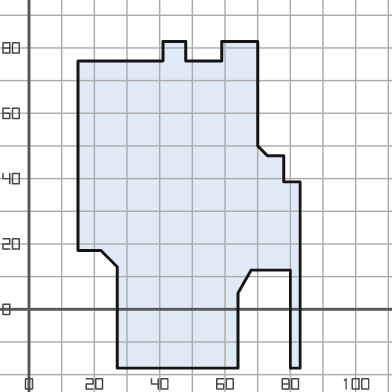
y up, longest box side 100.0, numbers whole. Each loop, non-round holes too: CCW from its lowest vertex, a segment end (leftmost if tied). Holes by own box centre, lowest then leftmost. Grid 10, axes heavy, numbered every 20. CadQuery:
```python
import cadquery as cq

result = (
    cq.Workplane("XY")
    .moveTo(27.0, -18.0)
    .lineTo(64.0, -18.0)
    .lineTo(64.0, 5.0)
    .lineTo(68.0, 12.0)
    .lineTo(80.0, 12.0)
    .lineTo(80.0, -18.0)
    .lineTo(83.0, -18.0)
    .lineTo(83.0, 39.0)
    .lineTo(78.0, 39.0)
    .lineTo(78.0, 47.0)
    .lineTo(73.0, 47.0)
    .lineTo(70.0, 50.0)
    .lineTo(70.0, 82.0)
    .lineTo(59.0, 82.0)
    .lineTo(59.0, 76.0)
    .lineTo(48.0, 76.0)
    .lineTo(48.0, 82.0)
    .lineTo(41.0, 82.0)
    .lineTo(41.0, 76.0)
    .lineTo(15.0, 76.0)
    .lineTo(15.0, 18.0)
    .lineTo(22.0, 18.0)
    .lineTo(27.0, 13.0)
    .close()
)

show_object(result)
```